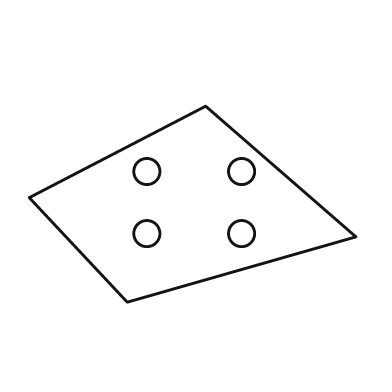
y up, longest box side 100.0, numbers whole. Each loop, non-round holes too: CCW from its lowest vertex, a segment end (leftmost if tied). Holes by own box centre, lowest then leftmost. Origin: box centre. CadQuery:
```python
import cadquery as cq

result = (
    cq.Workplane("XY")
    .moveTo(-20.0, -30.0)
    .lineTo(50.0, -10.0)
    .lineTo(4.0, 30.0)
    .lineTo(-50.0, 2.0)
    .close()
    .moveTo(-14.0, -9.0)
    .circle(4.0)
    .moveTo(15.0, -9.0)
    .circle(4.0)
    .moveTo(-14.0, 10.0)
    .circle(4.0)
    .moveTo(15.0, 10.0)
    .circle(4.0)
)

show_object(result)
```